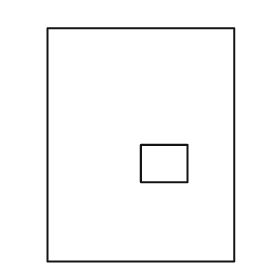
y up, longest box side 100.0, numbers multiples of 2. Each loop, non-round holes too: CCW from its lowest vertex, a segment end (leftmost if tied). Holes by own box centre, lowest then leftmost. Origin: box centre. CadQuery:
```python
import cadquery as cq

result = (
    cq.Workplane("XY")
    .moveTo(-40.0, -50.0)
    .lineTo(40.0, -50.0)
    .lineTo(40.0, 50.0)
    .lineTo(-40.0, 50.0)
    .close()
    .moveTo(0.0, -16.0)
    .lineTo(20.0, -16.0)
    .lineTo(20.0, 0.0)
    .lineTo(0.0, 0.0)
    .close()
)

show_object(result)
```